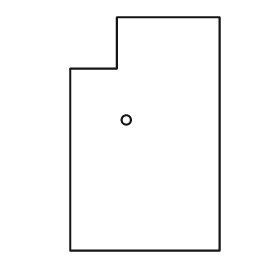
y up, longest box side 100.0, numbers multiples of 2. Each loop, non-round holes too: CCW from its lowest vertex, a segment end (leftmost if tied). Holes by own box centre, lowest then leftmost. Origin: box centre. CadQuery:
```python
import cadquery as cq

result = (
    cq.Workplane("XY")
    .moveTo(-32.0, -50.0)
    .lineTo(32.0, -50.0)
    .lineTo(32.0, 50.0)
    .lineTo(-12.0, 50.0)
    .lineTo(-12.0, 28.0)
    .lineTo(-32.0, 28.0)
    .close()
    .moveTo(-8.0, 6.0)
    .circle(2.0)
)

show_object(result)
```